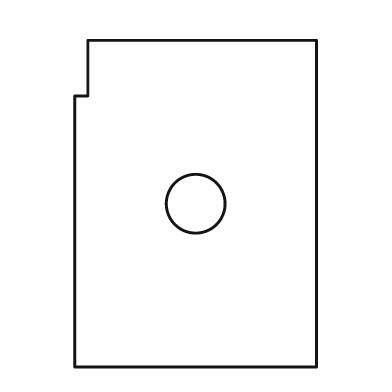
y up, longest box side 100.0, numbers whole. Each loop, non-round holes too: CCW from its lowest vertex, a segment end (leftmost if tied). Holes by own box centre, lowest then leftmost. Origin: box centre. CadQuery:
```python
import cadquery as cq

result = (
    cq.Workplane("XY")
    .moveTo(-37.0, -50.0)
    .lineTo(37.0, -50.0)
    .lineTo(37.0, 50.0)
    .lineTo(-33.0, 50.0)
    .lineTo(-33.0, 33.0)
    .lineTo(-37.0, 33.0)
    .close()
    .moveTo(0.0, 0.0)
    .circle(9.0)
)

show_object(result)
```